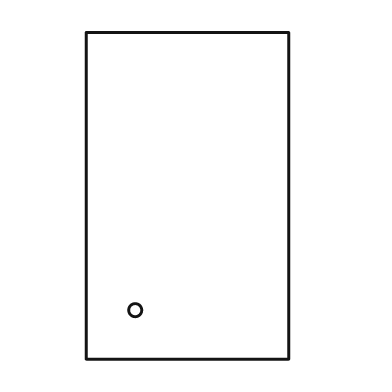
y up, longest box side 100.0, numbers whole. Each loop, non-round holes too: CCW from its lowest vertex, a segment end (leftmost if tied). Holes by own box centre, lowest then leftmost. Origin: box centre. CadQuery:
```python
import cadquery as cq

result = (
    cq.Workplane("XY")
    .moveTo(-31.0, -50.0)
    .lineTo(31.0, -50.0)
    .lineTo(31.0, 50.0)
    .lineTo(-31.0, 50.0)
    .close()
    .moveTo(-16.0, -35.0)
    .circle(2.0)
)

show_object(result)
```